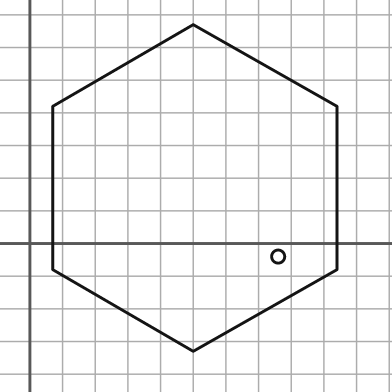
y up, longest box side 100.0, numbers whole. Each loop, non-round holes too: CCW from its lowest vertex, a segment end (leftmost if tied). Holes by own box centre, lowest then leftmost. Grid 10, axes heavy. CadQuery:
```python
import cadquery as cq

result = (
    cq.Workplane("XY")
    .moveTo(50.0, -33.0)
    .lineTo(94.0, -8.0)
    .lineTo(94.0, 42.0)
    .lineTo(50.0, 67.0)
    .lineTo(7.0, 42.0)
    .lineTo(7.0, -8.0)
    .close()
    .moveTo(76.0, -4.0)
    .circle(2.0)
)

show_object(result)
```